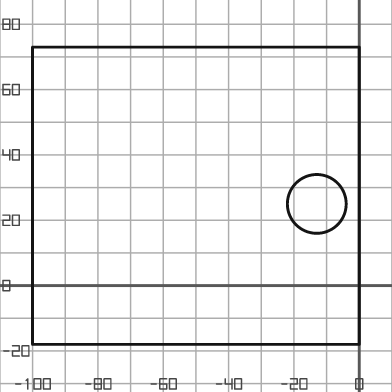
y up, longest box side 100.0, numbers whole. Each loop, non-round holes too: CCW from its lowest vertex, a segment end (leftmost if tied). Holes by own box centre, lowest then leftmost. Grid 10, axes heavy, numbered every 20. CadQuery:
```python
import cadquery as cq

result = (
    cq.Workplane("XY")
    .moveTo(-100.0, -18.0)
    .lineTo(0.0, -18.0)
    .lineTo(0.0, 73.0)
    .lineTo(-100.0, 73.0)
    .close()
    .moveTo(-13.0, 25.0)
    .circle(9.0)
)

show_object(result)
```